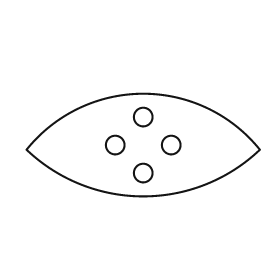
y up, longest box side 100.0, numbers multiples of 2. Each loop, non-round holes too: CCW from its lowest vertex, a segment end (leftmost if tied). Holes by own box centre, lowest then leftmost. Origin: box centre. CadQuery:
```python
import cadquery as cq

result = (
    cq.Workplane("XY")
    .moveTo(-50.0, -2.0)
    .threePointArc((0.0, -22.0), (50.0, -2.0))
    .threePointArc((0.0, 22.0), (-50.0, -2.0))
    .close()
    .moveTo(0.0, -12.0)
    .circle(4.0)
    .moveTo(-12.0, 0.0)
    .circle(4.0)
    .moveTo(12.0, 0.0)
    .circle(4.0)
    .moveTo(0.0, 12.0)
    .circle(4.0)
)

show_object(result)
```